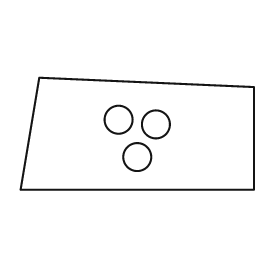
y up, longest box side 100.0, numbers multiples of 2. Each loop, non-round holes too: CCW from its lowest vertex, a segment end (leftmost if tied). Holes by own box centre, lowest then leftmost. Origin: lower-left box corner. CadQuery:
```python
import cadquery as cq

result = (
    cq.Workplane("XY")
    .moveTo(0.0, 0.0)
    .lineTo(100.0, 0.0)
    .lineTo(100.0, 44.0)
    .lineTo(8.0, 48.0)
    .close()
    .moveTo(50.0, 14.0)
    .circle(6.0)
    .moveTo(58.0, 28.0)
    .circle(6.0)
    .moveTo(42.0, 30.0)
    .circle(6.0)
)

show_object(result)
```